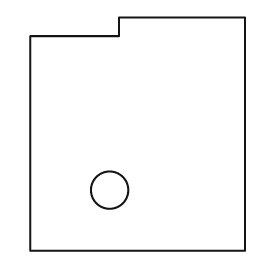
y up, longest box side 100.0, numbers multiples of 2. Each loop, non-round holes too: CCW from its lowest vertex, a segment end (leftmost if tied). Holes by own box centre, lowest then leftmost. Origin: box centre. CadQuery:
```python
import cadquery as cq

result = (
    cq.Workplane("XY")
    .moveTo(-46.0, -50.0)
    .lineTo(46.0, -50.0)
    .lineTo(46.0, 50.0)
    .lineTo(-8.0, 50.0)
    .lineTo(-8.0, 42.0)
    .lineTo(-46.0, 42.0)
    .close()
    .moveTo(-12.0, -24.0)
    .circle(8.0)
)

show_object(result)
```